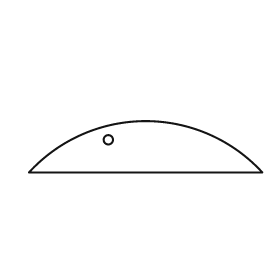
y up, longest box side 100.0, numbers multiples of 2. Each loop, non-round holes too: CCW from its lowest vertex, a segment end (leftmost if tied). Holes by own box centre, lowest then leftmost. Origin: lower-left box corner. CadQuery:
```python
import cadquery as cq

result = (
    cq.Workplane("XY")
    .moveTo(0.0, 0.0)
    .lineTo(100.0, 0.0)
    .threePointArc((50.0, 22.0), (0.0, 0.0))
    .close()
    .moveTo(34.0, 14.0)
    .circle(2.0)
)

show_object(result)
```